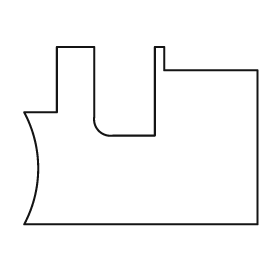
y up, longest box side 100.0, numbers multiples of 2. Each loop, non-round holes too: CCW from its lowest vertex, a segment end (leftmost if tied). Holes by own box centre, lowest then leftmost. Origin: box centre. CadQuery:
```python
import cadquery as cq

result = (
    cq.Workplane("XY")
    .moveTo(-50.0, -38.0)
    .lineTo(50.0, -38.0)
    .lineTo(50.0, 28.0)
    .lineTo(10.0, 28.0)
    .lineTo(10.0, 38.0)
    .lineTo(6.0, 38.0)
    .lineTo(6.0, 0.0)
    .lineTo(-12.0, 0.0)
    .threePointArc((-18.0, 2.0), (-20.0, 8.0))
    .lineTo(-20.0, 38.0)
    .lineTo(-36.0, 38.0)
    .lineTo(-36.0, 10.0)
    .lineTo(-50.0, 10.0)
    .threePointArc((-44.0, -14.0), (-50.0, -38.0))
    .close()
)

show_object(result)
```